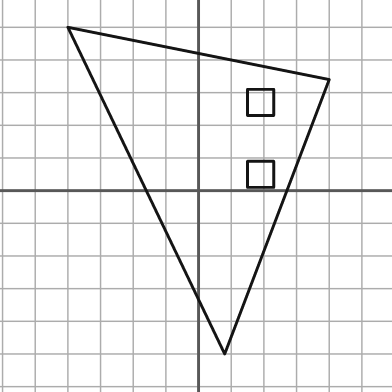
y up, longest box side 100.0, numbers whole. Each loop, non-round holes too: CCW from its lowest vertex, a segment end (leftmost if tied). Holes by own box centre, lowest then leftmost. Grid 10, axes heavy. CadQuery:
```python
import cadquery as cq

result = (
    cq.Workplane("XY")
    .moveTo(8.0, -50.0)
    .lineTo(40.0, 34.0)
    .lineTo(-40.0, 50.0)
    .close()
    .moveTo(15.0, 1.0)
    .lineTo(23.0, 1.0)
    .lineTo(23.0, 9.0)
    .lineTo(15.0, 9.0)
    .close()
    .moveTo(15.0, 23.0)
    .lineTo(23.0, 23.0)
    .lineTo(23.0, 31.0)
    .lineTo(15.0, 31.0)
    .close()
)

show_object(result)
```